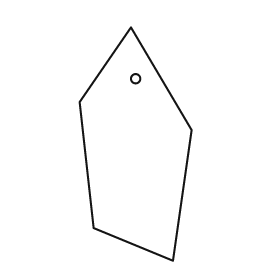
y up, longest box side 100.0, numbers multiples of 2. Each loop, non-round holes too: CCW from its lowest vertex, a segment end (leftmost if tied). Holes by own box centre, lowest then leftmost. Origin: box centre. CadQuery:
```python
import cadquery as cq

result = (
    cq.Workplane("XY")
    .moveTo(16.0, -50.0)
    .lineTo(24.0, 6.0)
    .lineTo(-2.0, 50.0)
    .lineTo(-24.0, 18.0)
    .lineTo(-18.0, -36.0)
    .close()
    .moveTo(0.0, 28.0)
    .circle(2.0)
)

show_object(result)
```